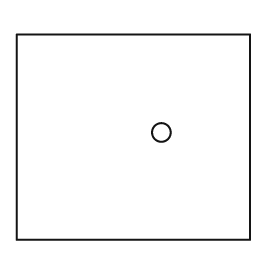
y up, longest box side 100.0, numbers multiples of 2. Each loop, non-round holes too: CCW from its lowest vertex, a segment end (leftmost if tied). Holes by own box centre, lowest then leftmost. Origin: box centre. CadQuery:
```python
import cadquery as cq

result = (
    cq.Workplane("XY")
    .moveTo(-50.0, -44.0)
    .lineTo(50.0, -44.0)
    .lineTo(50.0, 44.0)
    .lineTo(-50.0, 44.0)
    .close()
    .moveTo(12.0, 2.0)
    .circle(4.0)
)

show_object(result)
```